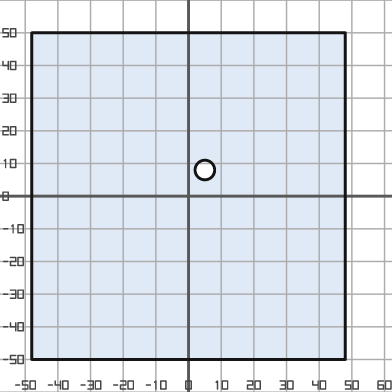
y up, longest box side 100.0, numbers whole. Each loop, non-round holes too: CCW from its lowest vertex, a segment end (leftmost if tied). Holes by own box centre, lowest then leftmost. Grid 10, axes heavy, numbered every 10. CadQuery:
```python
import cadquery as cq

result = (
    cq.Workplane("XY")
    .moveTo(-48.0, -50.0)
    .lineTo(48.0, -50.0)
    .lineTo(48.0, 50.0)
    .lineTo(-48.0, 50.0)
    .close()
    .moveTo(5.0, 8.0)
    .circle(3.0)
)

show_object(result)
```